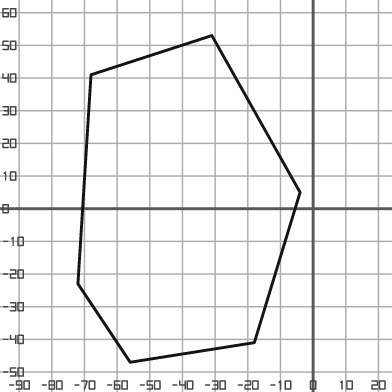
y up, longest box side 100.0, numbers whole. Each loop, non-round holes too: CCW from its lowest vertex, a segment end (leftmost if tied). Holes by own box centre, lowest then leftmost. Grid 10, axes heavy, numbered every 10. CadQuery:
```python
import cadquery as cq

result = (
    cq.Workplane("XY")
    .moveTo(-56.0, -47.0)
    .lineTo(-18.0, -41.0)
    .lineTo(-4.0, 5.0)
    .lineTo(-31.0, 53.0)
    .lineTo(-68.0, 41.0)
    .lineTo(-72.0, -23.0)
    .close()
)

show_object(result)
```